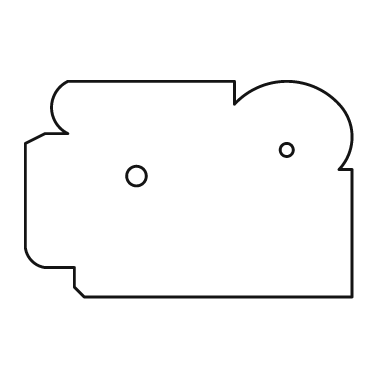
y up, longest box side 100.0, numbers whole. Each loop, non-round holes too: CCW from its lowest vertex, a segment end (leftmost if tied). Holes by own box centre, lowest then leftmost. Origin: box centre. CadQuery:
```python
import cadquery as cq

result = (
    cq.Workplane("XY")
    .moveTo(-32.0, -33.0)
    .lineTo(50.0, -33.0)
    .lineTo(50.0, 6.0)
    .lineTo(46.0, 6.0)
    .threePointArc((50.0, 16.0), (46.0, 26.0))
    .threePointArc((30.0, 33.0), (14.0, 26.0))
    .lineTo(14.0, 33.0)
    .lineTo(-37.0, 33.0)
    .threePointArc((-42.0, 25.0), (-37.0, 17.0))
    .lineTo(-44.0, 17.0)
    .lineTo(-50.0, 14.0)
    .lineTo(-50.0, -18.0)
    .threePointArc((-48.0, -22.0), (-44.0, -24.0))
    .lineTo(-35.0, -24.0)
    .lineTo(-35.0, -30.0)
    .close()
    .moveTo(-16.0, 4.0)
    .circle(3.0)
    .moveTo(30.0, 12.0)
    .circle(2.0)
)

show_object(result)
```